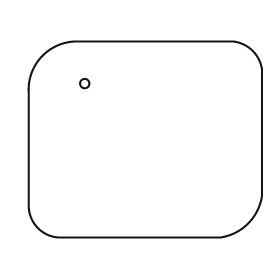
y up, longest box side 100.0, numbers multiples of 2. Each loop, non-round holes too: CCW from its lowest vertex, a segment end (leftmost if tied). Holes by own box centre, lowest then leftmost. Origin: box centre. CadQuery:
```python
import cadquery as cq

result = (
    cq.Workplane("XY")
    .moveTo(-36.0, -42.0)
    .lineTo(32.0, -42.0)
    .threePointArc((44.0, -36.0), (50.0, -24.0))
    .lineTo(50.0, 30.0)
    .threePointArc((46.0, 38.0), (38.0, 42.0))
    .lineTo(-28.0, 42.0)
    .threePointArc((-44.0, 36.0), (-50.0, 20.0))
    .lineTo(-50.0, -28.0)
    .threePointArc((-46.0, -38.0), (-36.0, -42.0))
    .close()
    .moveTo(-26.0, 24.0)
    .circle(2.0)
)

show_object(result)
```